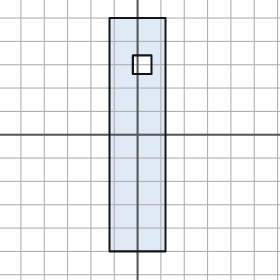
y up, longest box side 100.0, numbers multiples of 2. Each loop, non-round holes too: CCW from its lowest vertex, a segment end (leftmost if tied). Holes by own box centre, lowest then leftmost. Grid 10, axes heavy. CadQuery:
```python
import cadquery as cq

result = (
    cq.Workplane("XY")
    .moveTo(-12.0, -50.0)
    .lineTo(12.0, -50.0)
    .lineTo(12.0, 50.0)
    .lineTo(-12.0, 50.0)
    .close()
    .moveTo(-2.0, 26.0)
    .lineTo(6.0, 26.0)
    .lineTo(6.0, 34.0)
    .lineTo(-2.0, 34.0)
    .close()
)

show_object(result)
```